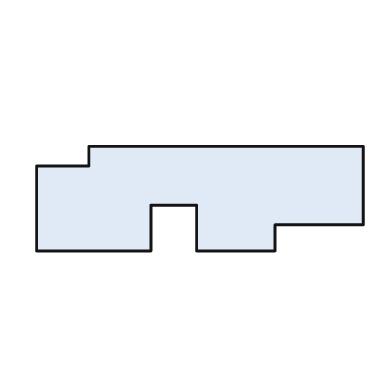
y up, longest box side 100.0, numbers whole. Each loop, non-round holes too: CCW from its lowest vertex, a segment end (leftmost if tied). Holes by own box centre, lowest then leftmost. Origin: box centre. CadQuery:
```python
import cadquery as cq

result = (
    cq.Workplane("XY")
    .moveTo(-50.0, -16.0)
    .lineTo(-15.0, -16.0)
    .lineTo(-15.0, -2.0)
    .lineTo(-1.0, -2.0)
    .lineTo(-1.0, -16.0)
    .lineTo(23.0, -16.0)
    .lineTo(23.0, -8.0)
    .lineTo(50.0, -8.0)
    .lineTo(50.0, 16.0)
    .lineTo(-34.0, 16.0)
    .lineTo(-34.0, 10.0)
    .lineTo(-50.0, 10.0)
    .close()
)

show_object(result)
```